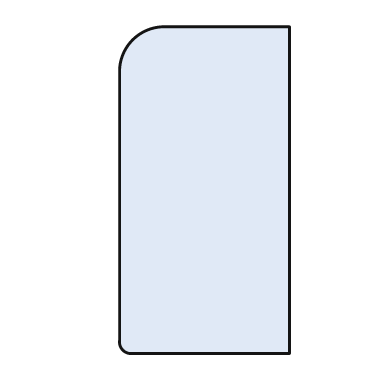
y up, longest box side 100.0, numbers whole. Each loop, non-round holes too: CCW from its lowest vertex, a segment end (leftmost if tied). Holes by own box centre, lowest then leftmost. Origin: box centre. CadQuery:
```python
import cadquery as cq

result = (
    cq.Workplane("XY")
    .moveTo(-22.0, -50.0)
    .lineTo(26.0, -50.0)
    .lineTo(26.0, 50.0)
    .lineTo(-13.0, 50.0)
    .threePointArc((-22.0, 46.0), (-26.0, 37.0))
    .lineTo(-26.0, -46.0)
    .threePointArc((-25.0, -49.0), (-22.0, -50.0))
    .close()
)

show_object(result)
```